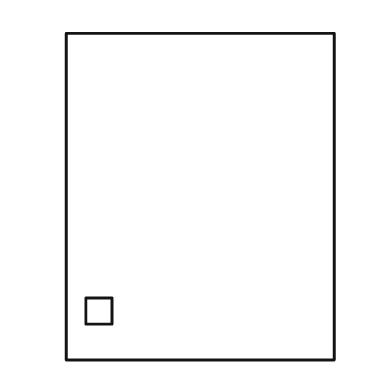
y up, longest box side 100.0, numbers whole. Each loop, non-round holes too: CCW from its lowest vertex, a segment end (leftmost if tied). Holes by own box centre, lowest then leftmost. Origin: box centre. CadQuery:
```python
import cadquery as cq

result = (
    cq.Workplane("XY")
    .moveTo(-41.0, -50.0)
    .lineTo(41.0, -50.0)
    .lineTo(41.0, 50.0)
    .lineTo(-41.0, 50.0)
    .close()
    .moveTo(-35.0, -39.0)
    .lineTo(-27.0, -39.0)
    .lineTo(-27.0, -31.0)
    .lineTo(-35.0, -31.0)
    .close()
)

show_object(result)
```